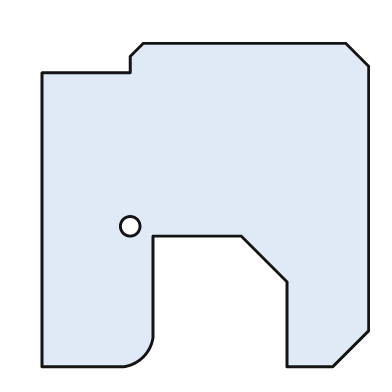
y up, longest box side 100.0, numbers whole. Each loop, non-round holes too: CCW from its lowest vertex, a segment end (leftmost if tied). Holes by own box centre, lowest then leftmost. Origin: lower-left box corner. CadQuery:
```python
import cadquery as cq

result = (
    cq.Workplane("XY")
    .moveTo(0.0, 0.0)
    .lineTo(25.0, 0.0)
    .threePointArc((31.0, 3.0), (34.0, 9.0))
    .lineTo(34.0, 40.0)
    .lineTo(61.0, 40.0)
    .lineTo(75.0, 26.0)
    .lineTo(75.0, 0.0)
    .lineTo(89.0, 0.0)
    .lineTo(100.0, 11.0)
    .lineTo(100.0, 92.0)
    .lineTo(93.0, 99.0)
    .lineTo(31.0, 99.0)
    .lineTo(27.0, 95.0)
    .lineTo(27.0, 90.0)
    .lineTo(0.0, 90.0)
    .close()
    .moveTo(27.0, 43.0)
    .circle(3.0)
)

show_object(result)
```